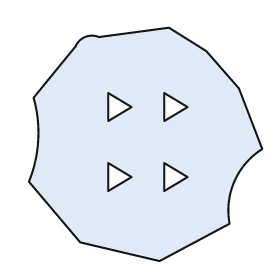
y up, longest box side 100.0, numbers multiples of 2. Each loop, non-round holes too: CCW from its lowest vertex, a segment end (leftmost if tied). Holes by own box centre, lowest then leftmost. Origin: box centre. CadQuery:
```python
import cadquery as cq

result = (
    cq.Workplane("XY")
    .moveTo(6.0, -50.0)
    .lineTo(36.0, -34.0)
    .threePointArc((38.0, -16.0), (50.0, -2.0))
    .lineTo(40.0, 24.0)
    .lineTo(26.0, 40.0)
    .lineTo(10.0, 50.0)
    .lineTo(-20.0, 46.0)
    .threePointArc((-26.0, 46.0), (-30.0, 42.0))
    .lineTo(-48.0, 20.0)
    .threePointArc((-46.0, 2.0), (-50.0, -16.0))
    .lineTo(-28.0, -42.0)
    .close()
    .moveTo(-16.0, -20.0)
    .lineTo(-6.0, -14.0)
    .lineTo(-16.0, -8.0)
    .close()
    .moveTo(8.0, -20.0)
    .lineTo(18.0, -14.0)
    .lineTo(8.0, -8.0)
    .close()
    .moveTo(-16.0, 10.0)
    .lineTo(-6.0, 16.0)
    .lineTo(-16.0, 22.0)
    .close()
    .moveTo(8.0, 10.0)
    .lineTo(18.0, 16.0)
    .lineTo(8.0, 22.0)
    .close()
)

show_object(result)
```